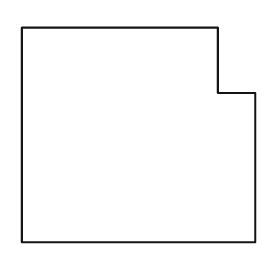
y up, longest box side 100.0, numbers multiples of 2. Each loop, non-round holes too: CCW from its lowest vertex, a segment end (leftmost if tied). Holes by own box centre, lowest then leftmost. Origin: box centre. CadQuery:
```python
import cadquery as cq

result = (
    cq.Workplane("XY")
    .moveTo(-50.0, -46.0)
    .lineTo(50.0, -46.0)
    .lineTo(50.0, 18.0)
    .lineTo(34.0, 18.0)
    .lineTo(34.0, 46.0)
    .lineTo(-50.0, 46.0)
    .close()
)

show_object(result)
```